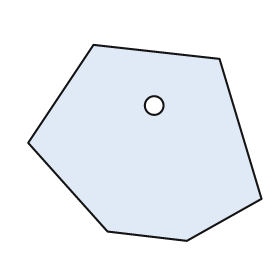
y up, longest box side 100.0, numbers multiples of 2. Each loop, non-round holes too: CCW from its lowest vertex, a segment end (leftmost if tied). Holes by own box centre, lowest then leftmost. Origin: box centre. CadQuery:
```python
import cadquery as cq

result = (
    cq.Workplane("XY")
    .moveTo(18.0, -42.0)
    .lineTo(50.0, -24.0)
    .lineTo(32.0, 36.0)
    .lineTo(-22.0, 42.0)
    .lineTo(-50.0, 0.0)
    .lineTo(-16.0, -38.0)
    .close()
    .moveTo(4.0, 16.0)
    .circle(4.0)
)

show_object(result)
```